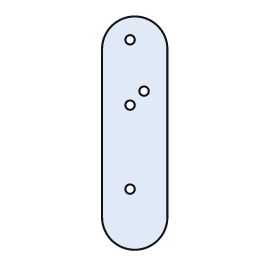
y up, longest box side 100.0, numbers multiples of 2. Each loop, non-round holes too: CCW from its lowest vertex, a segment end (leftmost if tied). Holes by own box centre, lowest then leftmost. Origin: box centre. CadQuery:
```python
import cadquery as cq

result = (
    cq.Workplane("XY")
    .moveTo(-14.0, -36.0)
    .threePointArc((0.0, -50.0), (14.0, -36.0))
    .lineTo(14.0, 36.0)
    .threePointArc((0.0, 50.0), (-14.0, 36.0))
    .close()
    .moveTo(-2.0, -24.0)
    .circle(2.0)
    .moveTo(-2.0, 12.0)
    .circle(2.0)
    .moveTo(4.0, 18.0)
    .circle(2.0)
    .moveTo(-2.0, 40.0)
    .circle(2.0)
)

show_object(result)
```